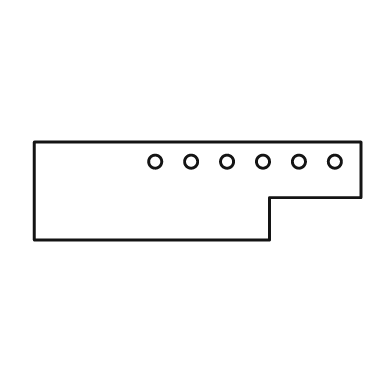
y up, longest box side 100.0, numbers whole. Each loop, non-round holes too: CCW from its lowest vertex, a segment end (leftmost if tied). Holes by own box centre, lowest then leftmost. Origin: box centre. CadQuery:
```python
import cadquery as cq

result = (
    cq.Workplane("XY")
    .moveTo(-50.0, -15.0)
    .lineTo(22.0, -15.0)
    .lineTo(22.0, -2.0)
    .lineTo(50.0, -2.0)
    .lineTo(50.0, 15.0)
    .lineTo(-50.0, 15.0)
    .close()
    .moveTo(-13.0, 9.0)
    .circle(2.0)
    .moveTo(-2.0, 9.0)
    .circle(2.0)
    .moveTo(9.0, 9.0)
    .circle(2.0)
    .moveTo(20.0, 9.0)
    .circle(2.0)
    .moveTo(31.0, 9.0)
    .circle(2.0)
    .moveTo(42.0, 9.0)
    .circle(2.0)
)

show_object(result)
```